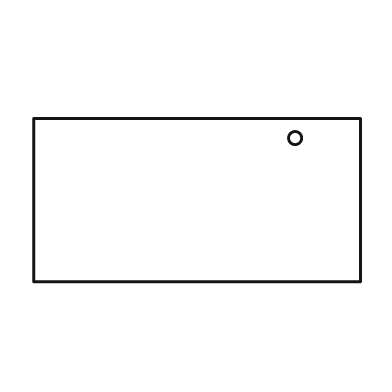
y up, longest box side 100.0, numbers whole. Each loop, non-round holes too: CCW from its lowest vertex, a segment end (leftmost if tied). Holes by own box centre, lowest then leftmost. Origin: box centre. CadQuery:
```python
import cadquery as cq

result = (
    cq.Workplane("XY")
    .moveTo(-50.0, -25.0)
    .lineTo(50.0, -25.0)
    .lineTo(50.0, 25.0)
    .lineTo(-50.0, 25.0)
    .close()
    .moveTo(30.0, 19.0)
    .circle(2.0)
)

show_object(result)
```